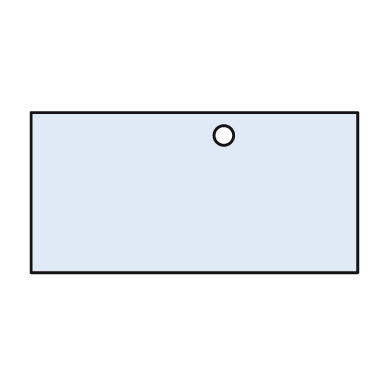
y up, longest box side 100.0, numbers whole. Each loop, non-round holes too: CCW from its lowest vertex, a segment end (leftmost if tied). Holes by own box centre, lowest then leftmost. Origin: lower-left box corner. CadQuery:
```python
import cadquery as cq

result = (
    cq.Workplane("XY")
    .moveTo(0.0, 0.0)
    .lineTo(100.0, 0.0)
    .lineTo(100.0, 49.0)
    .lineTo(0.0, 49.0)
    .close()
    .moveTo(59.0, 42.0)
    .circle(3.0)
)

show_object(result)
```